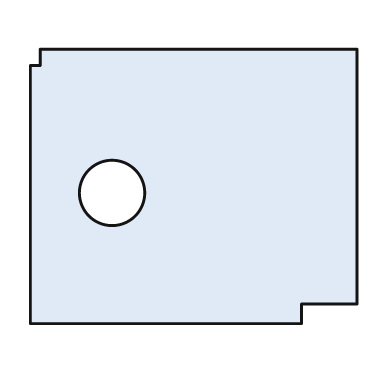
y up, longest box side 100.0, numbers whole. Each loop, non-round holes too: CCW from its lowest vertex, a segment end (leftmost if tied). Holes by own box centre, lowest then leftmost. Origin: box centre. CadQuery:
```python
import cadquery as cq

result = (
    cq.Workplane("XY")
    .moveTo(-50.0, -42.0)
    .lineTo(33.0, -42.0)
    .lineTo(33.0, -36.0)
    .lineTo(50.0, -36.0)
    .lineTo(50.0, 42.0)
    .lineTo(-47.0, 42.0)
    .lineTo(-47.0, 37.0)
    .lineTo(-50.0, 37.0)
    .close()
    .moveTo(-25.0, -2.0)
    .circle(10.0)
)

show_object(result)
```